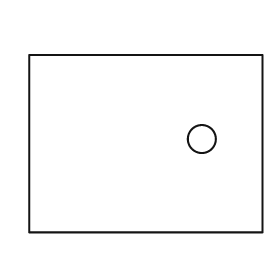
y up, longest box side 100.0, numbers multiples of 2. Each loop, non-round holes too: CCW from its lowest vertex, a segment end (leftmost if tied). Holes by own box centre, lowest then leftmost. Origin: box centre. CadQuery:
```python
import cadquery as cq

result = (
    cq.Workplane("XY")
    .moveTo(-50.0, -38.0)
    .lineTo(50.0, -38.0)
    .lineTo(50.0, 38.0)
    .lineTo(-50.0, 38.0)
    .close()
    .moveTo(24.0, 2.0)
    .circle(6.0)
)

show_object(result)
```